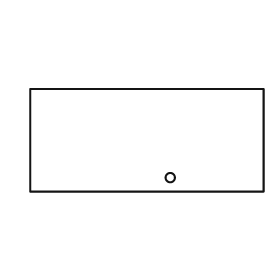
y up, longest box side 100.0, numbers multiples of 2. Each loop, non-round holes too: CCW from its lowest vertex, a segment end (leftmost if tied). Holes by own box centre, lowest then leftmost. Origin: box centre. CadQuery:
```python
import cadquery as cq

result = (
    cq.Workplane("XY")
    .moveTo(-50.0, -22.0)
    .lineTo(50.0, -22.0)
    .lineTo(50.0, 22.0)
    .lineTo(-50.0, 22.0)
    .close()
    .moveTo(10.0, -16.0)
    .circle(2.0)
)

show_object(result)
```